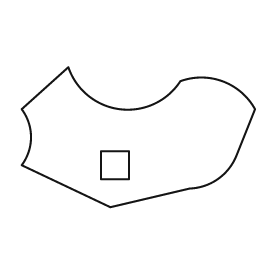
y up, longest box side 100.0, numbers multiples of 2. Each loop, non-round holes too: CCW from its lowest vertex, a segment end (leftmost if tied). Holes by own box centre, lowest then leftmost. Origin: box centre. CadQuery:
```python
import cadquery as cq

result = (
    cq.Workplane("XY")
    .moveTo(-12.0, -30.0)
    .lineTo(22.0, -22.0)
    .threePointArc((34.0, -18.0), (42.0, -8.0))
    .lineTo(50.0, 12.0)
    .threePointArc((36.0, 24.0), (18.0, 24.0))
    .threePointArc((-8.0, 12.0), (-30.0, 30.0))
    .lineTo(-50.0, 12.0)
    .threePointArc((-46.0, 0.0), (-50.0, -12.0))
    .close()
    .moveTo(-16.0, -18.0)
    .lineTo(-4.0, -18.0)
    .lineTo(-4.0, -6.0)
    .lineTo(-16.0, -6.0)
    .close()
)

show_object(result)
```